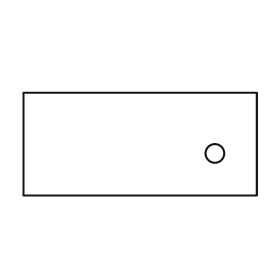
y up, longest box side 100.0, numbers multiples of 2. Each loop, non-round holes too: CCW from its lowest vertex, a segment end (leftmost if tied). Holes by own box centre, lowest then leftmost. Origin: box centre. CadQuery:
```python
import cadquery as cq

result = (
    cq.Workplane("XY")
    .moveTo(-50.0, -22.0)
    .lineTo(50.0, -22.0)
    .lineTo(50.0, 22.0)
    .lineTo(-50.0, 22.0)
    .close()
    .moveTo(32.0, -4.0)
    .circle(4.0)
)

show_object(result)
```